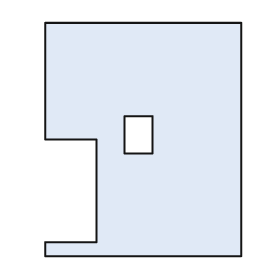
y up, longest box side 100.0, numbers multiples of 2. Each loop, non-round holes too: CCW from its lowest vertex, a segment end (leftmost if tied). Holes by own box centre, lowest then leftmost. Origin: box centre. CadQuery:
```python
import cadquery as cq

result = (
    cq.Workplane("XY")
    .moveTo(-42.0, -50.0)
    .lineTo(42.0, -50.0)
    .lineTo(42.0, 50.0)
    .lineTo(-42.0, 50.0)
    .lineTo(-42.0, 0.0)
    .lineTo(-20.0, 0.0)
    .lineTo(-20.0, -44.0)
    .lineTo(-42.0, -44.0)
    .close()
    .moveTo(-8.0, -6.0)
    .lineTo(4.0, -6.0)
    .lineTo(4.0, 10.0)
    .lineTo(-8.0, 10.0)
    .close()
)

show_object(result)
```